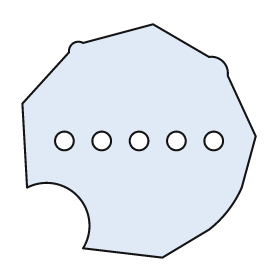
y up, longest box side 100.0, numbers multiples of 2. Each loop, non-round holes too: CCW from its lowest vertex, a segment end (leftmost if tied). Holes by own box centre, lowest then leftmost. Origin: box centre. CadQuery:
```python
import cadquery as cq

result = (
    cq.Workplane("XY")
    .moveTo(10.0, -50.0)
    .lineTo(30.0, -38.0)
    .threePointArc((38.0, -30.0), (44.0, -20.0))
    .lineTo(50.0, 2.0)
    .lineTo(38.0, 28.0)
    .threePointArc((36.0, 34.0), (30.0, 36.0))
    .lineTo(6.0, 50.0)
    .lineTo(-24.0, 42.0)
    .threePointArc((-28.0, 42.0), (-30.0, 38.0))
    .lineTo(-50.0, 16.0)
    .lineTo(-48.0, -20.0)
    .threePointArc((-26.0, -24.0), (-24.0, -46.0))
    .close()
    .moveTo(-32.0, 0.0)
    .circle(4.0)
    .moveTo(-16.0, 0.0)
    .circle(4.0)
    .moveTo(0.0, 0.0)
    .circle(4.0)
    .moveTo(16.0, 0.0)
    .circle(4.0)
    .moveTo(32.0, 0.0)
    .circle(4.0)
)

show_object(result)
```